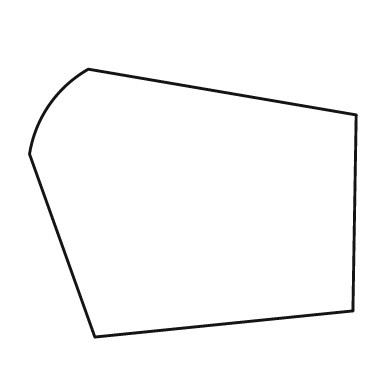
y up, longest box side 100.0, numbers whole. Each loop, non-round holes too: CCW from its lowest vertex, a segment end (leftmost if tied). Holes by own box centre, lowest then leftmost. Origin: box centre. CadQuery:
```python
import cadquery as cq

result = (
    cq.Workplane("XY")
    .moveTo(-30.0, -41.0)
    .lineTo(49.0, -33.0)
    .lineTo(50.0, 27.0)
    .lineTo(-32.0, 41.0)
    .threePointArc((-44.0, 30.0), (-50.0, 15.0))
    .close()
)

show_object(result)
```